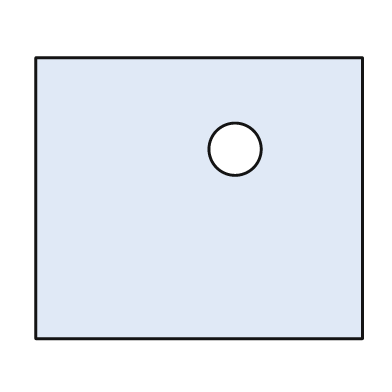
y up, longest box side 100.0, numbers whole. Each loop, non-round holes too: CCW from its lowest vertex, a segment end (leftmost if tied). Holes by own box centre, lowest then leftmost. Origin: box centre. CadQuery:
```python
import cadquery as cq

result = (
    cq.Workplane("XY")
    .moveTo(-50.0, -43.0)
    .lineTo(50.0, -43.0)
    .lineTo(50.0, 43.0)
    .lineTo(-50.0, 43.0)
    .close()
    .moveTo(11.0, 15.0)
    .circle(8.0)
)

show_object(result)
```